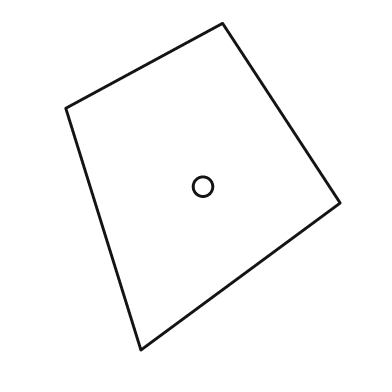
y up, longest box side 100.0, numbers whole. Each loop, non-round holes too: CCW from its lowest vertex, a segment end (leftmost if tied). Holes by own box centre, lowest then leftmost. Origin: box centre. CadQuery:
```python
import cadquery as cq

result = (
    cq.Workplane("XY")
    .moveTo(-19.0, -50.0)
    .lineTo(42.0, -5.0)
    .lineTo(6.0, 50.0)
    .lineTo(-42.0, 24.0)
    .close()
    .moveTo(0.0, 0.0)
    .circle(3.0)
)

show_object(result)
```